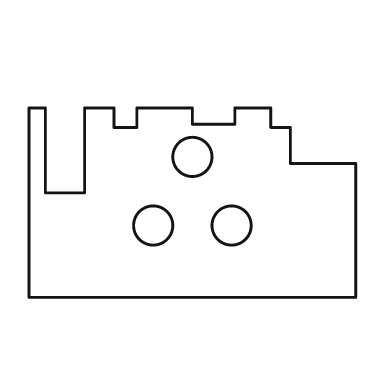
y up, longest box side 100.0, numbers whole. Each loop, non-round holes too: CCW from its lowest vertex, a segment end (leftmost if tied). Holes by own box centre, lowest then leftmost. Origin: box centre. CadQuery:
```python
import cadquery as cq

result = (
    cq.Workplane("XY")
    .moveTo(-50.0, -29.0)
    .lineTo(50.0, -29.0)
    .lineTo(50.0, 12.0)
    .lineTo(30.0, 12.0)
    .lineTo(30.0, 23.0)
    .lineTo(24.0, 23.0)
    .lineTo(24.0, 29.0)
    .lineTo(13.0, 29.0)
    .lineTo(13.0, 24.0)
    .lineTo(0.0, 24.0)
    .lineTo(0.0, 29.0)
    .lineTo(-17.0, 29.0)
    .lineTo(-17.0, 23.0)
    .lineTo(-24.0, 23.0)
    .lineTo(-24.0, 29.0)
    .lineTo(-33.0, 29.0)
    .lineTo(-33.0, 3.0)
    .lineTo(-45.0, 3.0)
    .lineTo(-45.0, 29.0)
    .lineTo(-50.0, 29.0)
    .close()
    .moveTo(-12.0, -7.0)
    .circle(6.0)
    .moveTo(12.0, -7.0)
    .circle(6.0)
    .moveTo(0.0, 14.0)
    .circle(6.0)
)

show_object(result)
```